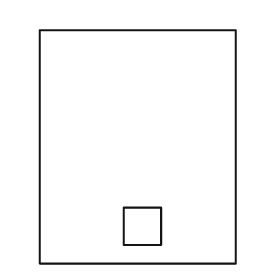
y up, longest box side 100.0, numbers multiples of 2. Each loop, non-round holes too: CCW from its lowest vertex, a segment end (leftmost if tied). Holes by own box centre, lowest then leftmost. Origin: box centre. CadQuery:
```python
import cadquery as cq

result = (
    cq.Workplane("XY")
    .moveTo(-42.0, -50.0)
    .lineTo(42.0, -50.0)
    .lineTo(42.0, 50.0)
    .lineTo(-42.0, 50.0)
    .close()
    .moveTo(-6.0, -42.0)
    .lineTo(10.0, -42.0)
    .lineTo(10.0, -26.0)
    .lineTo(-6.0, -26.0)
    .close()
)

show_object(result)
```